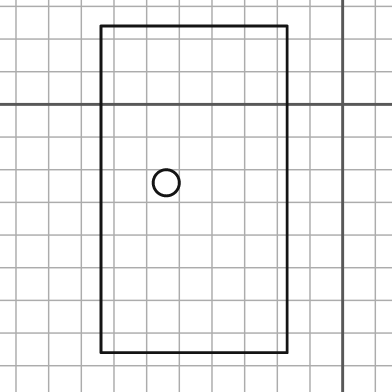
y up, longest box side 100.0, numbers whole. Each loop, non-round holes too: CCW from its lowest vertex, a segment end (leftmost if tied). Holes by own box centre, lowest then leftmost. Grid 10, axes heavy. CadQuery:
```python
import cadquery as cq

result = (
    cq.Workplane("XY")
    .moveTo(-74.0, -76.0)
    .lineTo(-17.0, -76.0)
    .lineTo(-17.0, 24.0)
    .lineTo(-74.0, 24.0)
    .close()
    .moveTo(-54.0, -24.0)
    .circle(4.0)
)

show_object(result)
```